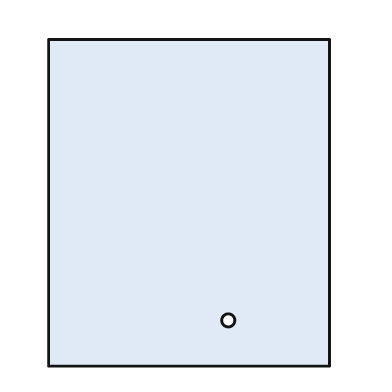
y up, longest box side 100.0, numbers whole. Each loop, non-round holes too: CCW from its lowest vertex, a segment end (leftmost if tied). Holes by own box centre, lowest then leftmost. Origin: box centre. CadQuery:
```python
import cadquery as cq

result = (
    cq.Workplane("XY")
    .moveTo(-43.0, -50.0)
    .lineTo(43.0, -50.0)
    .lineTo(43.0, 50.0)
    .lineTo(-43.0, 50.0)
    .close()
    .moveTo(12.0, -36.0)
    .circle(2.0)
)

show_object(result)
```